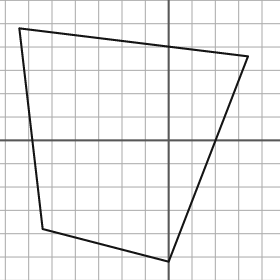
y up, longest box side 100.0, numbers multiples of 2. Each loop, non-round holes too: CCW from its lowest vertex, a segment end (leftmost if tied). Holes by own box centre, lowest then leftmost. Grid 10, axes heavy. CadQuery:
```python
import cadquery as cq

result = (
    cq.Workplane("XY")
    .moveTo(0.0, -52.0)
    .lineTo(34.0, 36.0)
    .lineTo(-64.0, 48.0)
    .lineTo(-54.0, -38.0)
    .close()
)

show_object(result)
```